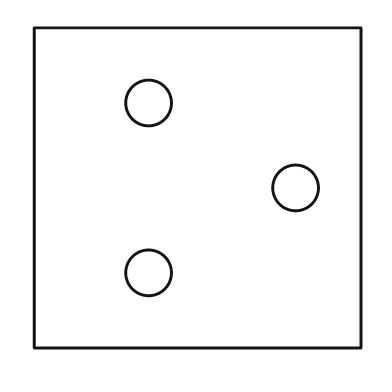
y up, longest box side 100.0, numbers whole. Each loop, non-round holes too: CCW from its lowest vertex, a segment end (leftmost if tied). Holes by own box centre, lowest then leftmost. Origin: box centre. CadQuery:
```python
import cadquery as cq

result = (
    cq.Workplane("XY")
    .moveTo(-50.0, -49.0)
    .lineTo(50.0, -49.0)
    .lineTo(50.0, 49.0)
    .lineTo(-50.0, 49.0)
    .close()
    .moveTo(-15.0, -26.0)
    .circle(7.0)
    .moveTo(30.0, 0.0)
    .circle(7.0)
    .moveTo(-15.0, 26.0)
    .circle(7.0)
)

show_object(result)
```